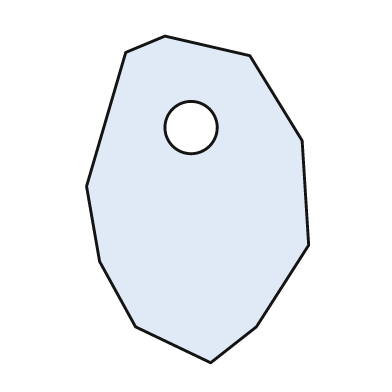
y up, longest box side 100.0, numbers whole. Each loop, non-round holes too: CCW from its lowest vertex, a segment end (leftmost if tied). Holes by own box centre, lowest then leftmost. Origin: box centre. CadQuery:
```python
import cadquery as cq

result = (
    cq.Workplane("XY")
    .moveTo(4.0, -50.0)
    .lineTo(18.0, -39.0)
    .lineTo(34.0, -14.0)
    .lineTo(32.0, 18.0)
    .lineTo(16.0, 44.0)
    .lineTo(-10.0, 50.0)
    .lineTo(-22.0, 45.0)
    .lineTo(-34.0, 4.0)
    .lineTo(-30.0, -19.0)
    .lineTo(-19.0, -39.0)
    .close()
    .moveTo(-2.0, 22.0)
    .circle(8.0)
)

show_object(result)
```